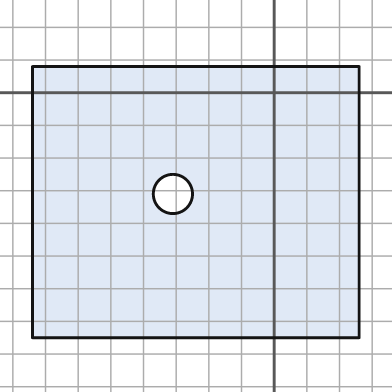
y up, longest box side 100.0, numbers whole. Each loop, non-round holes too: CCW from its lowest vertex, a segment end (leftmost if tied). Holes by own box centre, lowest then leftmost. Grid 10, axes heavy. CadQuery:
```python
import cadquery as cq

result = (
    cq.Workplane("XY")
    .moveTo(-74.0, -75.0)
    .lineTo(26.0, -75.0)
    .lineTo(26.0, 8.0)
    .lineTo(-74.0, 8.0)
    .close()
    .moveTo(-31.0, -31.0)
    .circle(6.0)
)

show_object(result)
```